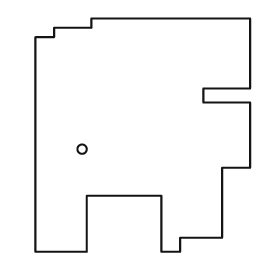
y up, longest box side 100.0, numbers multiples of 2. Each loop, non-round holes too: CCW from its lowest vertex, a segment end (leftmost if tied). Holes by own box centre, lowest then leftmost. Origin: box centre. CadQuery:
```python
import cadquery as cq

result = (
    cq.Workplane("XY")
    .moveTo(-46.0, -50.0)
    .lineTo(-24.0, -50.0)
    .lineTo(-24.0, -26.0)
    .lineTo(8.0, -26.0)
    .lineTo(8.0, -50.0)
    .lineTo(16.0, -50.0)
    .lineTo(16.0, -44.0)
    .lineTo(34.0, -44.0)
    .lineTo(34.0, -14.0)
    .lineTo(46.0, -14.0)
    .lineTo(46.0, 14.0)
    .lineTo(26.0, 14.0)
    .lineTo(26.0, 20.0)
    .lineTo(46.0, 20.0)
    .lineTo(46.0, 50.0)
    .lineTo(-22.0, 50.0)
    .lineTo(-22.0, 46.0)
    .lineTo(-38.0, 46.0)
    .lineTo(-38.0, 42.0)
    .lineTo(-46.0, 42.0)
    .close()
    .moveTo(-26.0, -6.0)
    .circle(2.0)
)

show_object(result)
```